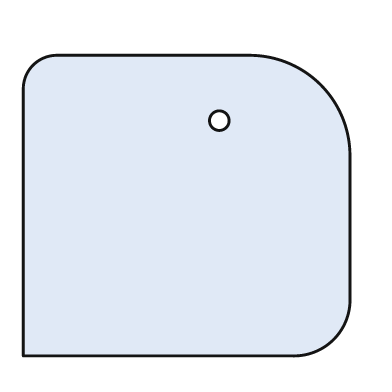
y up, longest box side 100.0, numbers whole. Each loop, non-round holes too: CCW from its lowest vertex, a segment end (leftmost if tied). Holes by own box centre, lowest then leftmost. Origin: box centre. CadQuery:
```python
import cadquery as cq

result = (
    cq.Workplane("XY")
    .moveTo(-50.0, -46.0)
    .lineTo(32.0, -46.0)
    .threePointArc((45.0, -41.0), (50.0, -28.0))
    .lineTo(50.0, 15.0)
    .threePointArc((41.0, 37.0), (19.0, 46.0))
    .lineTo(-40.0, 46.0)
    .threePointArc((-47.0, 43.0), (-50.0, 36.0))
    .close()
    .moveTo(10.0, 26.0)
    .circle(3.0)
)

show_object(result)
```